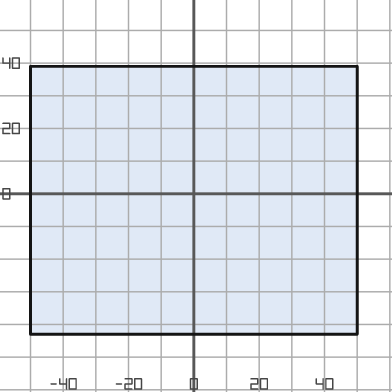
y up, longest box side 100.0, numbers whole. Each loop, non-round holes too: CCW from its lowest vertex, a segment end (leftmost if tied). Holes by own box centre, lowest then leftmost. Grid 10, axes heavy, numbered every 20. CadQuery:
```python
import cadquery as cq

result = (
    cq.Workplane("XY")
    .moveTo(-50.0, -43.0)
    .lineTo(50.0, -43.0)
    .lineTo(50.0, 39.0)
    .lineTo(-50.0, 39.0)
    .close()
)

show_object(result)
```